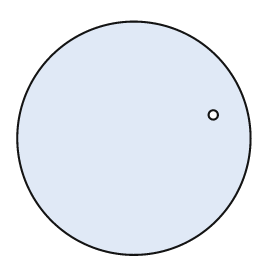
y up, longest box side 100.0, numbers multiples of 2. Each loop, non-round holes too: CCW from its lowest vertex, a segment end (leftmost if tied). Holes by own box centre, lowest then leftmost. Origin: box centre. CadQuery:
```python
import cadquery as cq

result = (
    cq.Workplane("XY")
    .moveTo(0.0, 0.0)
    .circle(50.0)
    .moveTo(34.0, 10.0)
    .circle(2.0)
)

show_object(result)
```